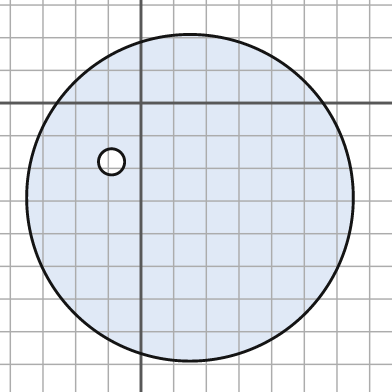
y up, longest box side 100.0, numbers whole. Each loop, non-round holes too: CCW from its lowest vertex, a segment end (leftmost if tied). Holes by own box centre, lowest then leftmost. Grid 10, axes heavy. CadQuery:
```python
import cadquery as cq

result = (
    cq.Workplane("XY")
    .moveTo(15.0, -29.0)
    .circle(50.0)
    .moveTo(-9.0, -18.0)
    .circle(4.0)
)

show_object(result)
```